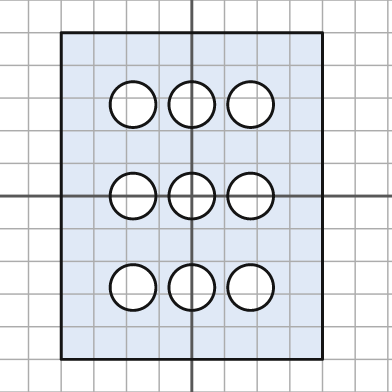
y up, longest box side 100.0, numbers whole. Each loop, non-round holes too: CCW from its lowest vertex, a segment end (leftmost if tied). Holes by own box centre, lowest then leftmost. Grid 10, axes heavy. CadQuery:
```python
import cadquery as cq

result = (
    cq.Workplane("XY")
    .moveTo(-40.0, -50.0)
    .lineTo(40.0, -50.0)
    .lineTo(40.0, 50.0)
    .lineTo(-40.0, 50.0)
    .close()
    .moveTo(-18.0, -28.0)
    .circle(7.0)
    .moveTo(0.0, -28.0)
    .circle(7.0)
    .moveTo(18.0, -28.0)
    .circle(7.0)
    .moveTo(-18.0, 0.0)
    .circle(7.0)
    .moveTo(0.0, 0.0)
    .circle(7.0)
    .moveTo(18.0, 0.0)
    .circle(7.0)
    .moveTo(-18.0, 28.0)
    .circle(7.0)
    .moveTo(0.0, 28.0)
    .circle(7.0)
    .moveTo(18.0, 28.0)
    .circle(7.0)
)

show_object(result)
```